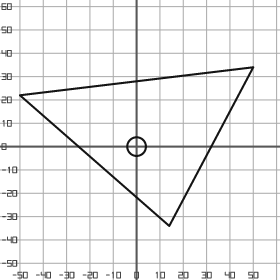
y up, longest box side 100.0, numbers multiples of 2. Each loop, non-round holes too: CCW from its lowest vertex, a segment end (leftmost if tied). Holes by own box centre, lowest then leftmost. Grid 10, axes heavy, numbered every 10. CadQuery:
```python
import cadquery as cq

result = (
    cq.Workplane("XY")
    .moveTo(14.0, -34.0)
    .lineTo(50.0, 34.0)
    .lineTo(-50.0, 22.0)
    .close()
    .moveTo(0.0, 0.0)
    .circle(4.0)
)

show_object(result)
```